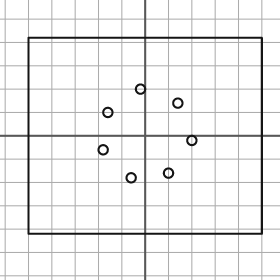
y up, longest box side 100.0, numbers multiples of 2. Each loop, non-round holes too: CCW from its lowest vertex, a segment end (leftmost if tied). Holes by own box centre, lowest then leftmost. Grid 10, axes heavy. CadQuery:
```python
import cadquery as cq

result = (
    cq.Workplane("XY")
    .moveTo(-50.0, -42.0)
    .lineTo(50.0, -42.0)
    .lineTo(50.0, 42.0)
    .lineTo(-50.0, 42.0)
    .close()
    .moveTo(-6.0, -18.0)
    .circle(2.0)
    .moveTo(10.0, -16.0)
    .circle(2.0)
    .moveTo(-18.0, -6.0)
    .circle(2.0)
    .moveTo(20.0, -2.0)
    .circle(2.0)
    .moveTo(-16.0, 10.0)
    .circle(2.0)
    .moveTo(14.0, 14.0)
    .circle(2.0)
    .moveTo(-2.0, 20.0)
    .circle(2.0)
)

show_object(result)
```